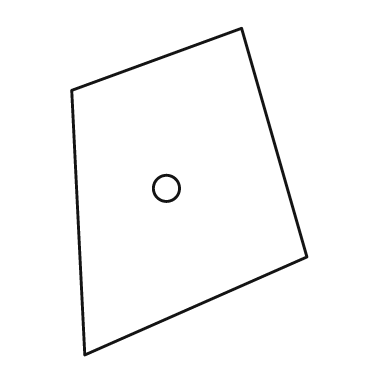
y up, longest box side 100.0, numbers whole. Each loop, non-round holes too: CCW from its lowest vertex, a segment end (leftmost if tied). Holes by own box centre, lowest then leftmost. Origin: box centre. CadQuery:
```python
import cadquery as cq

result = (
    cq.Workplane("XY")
    .moveTo(-32.0, -50.0)
    .lineTo(36.0, -20.0)
    .lineTo(16.0, 50.0)
    .lineTo(-36.0, 31.0)
    .close()
    .moveTo(-7.0, 1.0)
    .circle(4.0)
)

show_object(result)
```